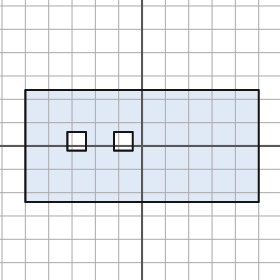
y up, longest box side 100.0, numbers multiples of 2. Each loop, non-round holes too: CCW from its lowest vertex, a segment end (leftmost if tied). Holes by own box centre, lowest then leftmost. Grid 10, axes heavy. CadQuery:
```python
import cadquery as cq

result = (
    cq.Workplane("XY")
    .moveTo(-50.0, -24.0)
    .lineTo(50.0, -24.0)
    .lineTo(50.0, 24.0)
    .lineTo(-50.0, 24.0)
    .close()
    .moveTo(-32.0, -2.0)
    .lineTo(-24.0, -2.0)
    .lineTo(-24.0, 6.0)
    .lineTo(-32.0, 6.0)
    .close()
    .moveTo(-12.0, -2.0)
    .lineTo(-4.0, -2.0)
    .lineTo(-4.0, 6.0)
    .lineTo(-12.0, 6.0)
    .close()
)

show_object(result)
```